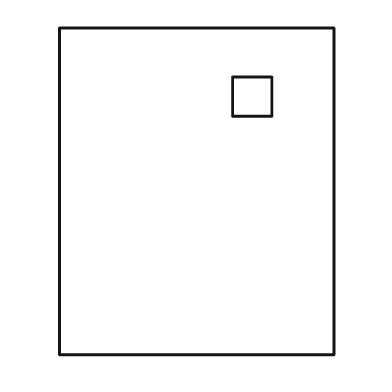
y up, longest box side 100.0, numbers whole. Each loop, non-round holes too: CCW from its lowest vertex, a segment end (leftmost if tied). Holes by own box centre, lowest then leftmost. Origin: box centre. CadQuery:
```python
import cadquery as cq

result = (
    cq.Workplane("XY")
    .moveTo(-42.0, -50.0)
    .lineTo(42.0, -50.0)
    .lineTo(42.0, 50.0)
    .lineTo(-42.0, 50.0)
    .close()
    .moveTo(11.0, 23.0)
    .lineTo(23.0, 23.0)
    .lineTo(23.0, 35.0)
    .lineTo(11.0, 35.0)
    .close()
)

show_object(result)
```